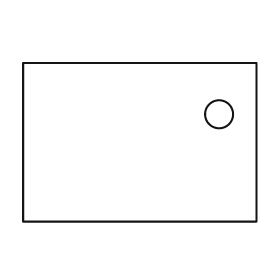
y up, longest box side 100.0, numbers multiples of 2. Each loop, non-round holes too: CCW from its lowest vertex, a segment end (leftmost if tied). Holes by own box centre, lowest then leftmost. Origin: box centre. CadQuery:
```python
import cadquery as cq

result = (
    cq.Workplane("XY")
    .moveTo(-50.0, -34.0)
    .lineTo(50.0, -34.0)
    .lineTo(50.0, 34.0)
    .lineTo(-50.0, 34.0)
    .close()
    .moveTo(34.0, 12.0)
    .circle(6.0)
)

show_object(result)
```